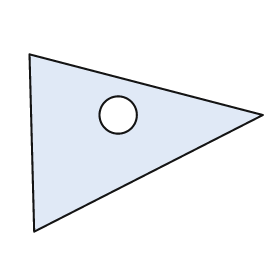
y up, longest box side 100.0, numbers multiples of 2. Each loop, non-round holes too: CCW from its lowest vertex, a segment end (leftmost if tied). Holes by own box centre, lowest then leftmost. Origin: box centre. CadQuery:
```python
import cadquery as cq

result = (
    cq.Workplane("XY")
    .moveTo(-48.0, -38.0)
    .lineTo(50.0, 12.0)
    .lineTo(-50.0, 38.0)
    .close()
    .moveTo(-12.0, 12.0)
    .circle(8.0)
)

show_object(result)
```